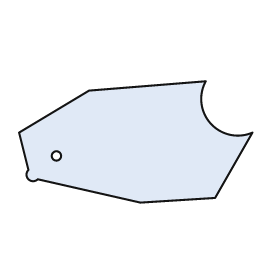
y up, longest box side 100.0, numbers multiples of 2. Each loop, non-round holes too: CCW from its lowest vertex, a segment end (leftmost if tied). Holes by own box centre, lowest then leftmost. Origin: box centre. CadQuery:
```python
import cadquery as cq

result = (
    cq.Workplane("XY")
    .moveTo(2.0, -26.0)
    .lineTo(34.0, -24.0)
    .lineTo(50.0, 4.0)
    .threePointArc((32.0, 8.0), (30.0, 26.0))
    .lineTo(-20.0, 22.0)
    .lineTo(-50.0, 4.0)
    .lineTo(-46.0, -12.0)
    .threePointArc((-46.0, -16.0), (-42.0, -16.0))
    .close()
    .moveTo(-34.0, -6.0)
    .circle(2.0)
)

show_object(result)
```